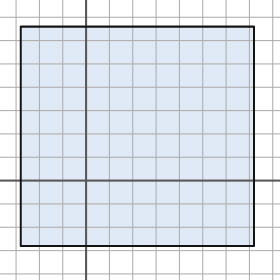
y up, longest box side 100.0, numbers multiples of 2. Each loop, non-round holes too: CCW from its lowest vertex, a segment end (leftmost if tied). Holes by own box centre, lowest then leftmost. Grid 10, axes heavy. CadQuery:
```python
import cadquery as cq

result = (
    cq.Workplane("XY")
    .moveTo(-28.0, -28.0)
    .lineTo(72.0, -28.0)
    .lineTo(72.0, 66.0)
    .lineTo(-28.0, 66.0)
    .close()
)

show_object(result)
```